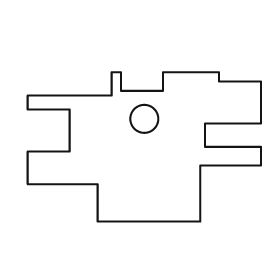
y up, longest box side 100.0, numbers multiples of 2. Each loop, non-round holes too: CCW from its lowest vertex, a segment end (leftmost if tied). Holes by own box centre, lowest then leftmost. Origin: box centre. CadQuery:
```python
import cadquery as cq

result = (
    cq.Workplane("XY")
    .moveTo(-20.0, -32.0)
    .lineTo(24.0, -32.0)
    .lineTo(24.0, -8.0)
    .lineTo(50.0, -8.0)
    .lineTo(50.0, 0.0)
    .lineTo(26.0, 0.0)
    .lineTo(26.0, 10.0)
    .lineTo(50.0, 10.0)
    .lineTo(50.0, 28.0)
    .lineTo(32.0, 28.0)
    .lineTo(32.0, 32.0)
    .lineTo(8.0, 32.0)
    .lineTo(8.0, 24.0)
    .lineTo(-10.0, 24.0)
    .lineTo(-10.0, 32.0)
    .lineTo(-14.0, 32.0)
    .lineTo(-14.0, 22.0)
    .lineTo(-50.0, 22.0)
    .lineTo(-50.0, 16.0)
    .lineTo(-32.0, 16.0)
    .lineTo(-32.0, -2.0)
    .lineTo(-50.0, -2.0)
    .lineTo(-50.0, -16.0)
    .lineTo(-20.0, -16.0)
    .close()
    .moveTo(0.0, 12.0)
    .circle(6.0)
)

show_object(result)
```